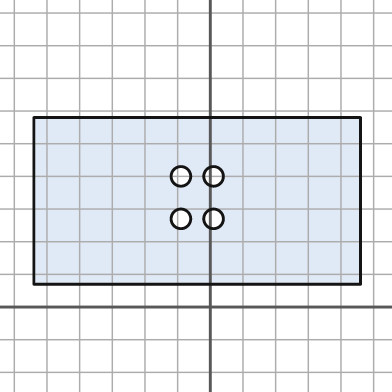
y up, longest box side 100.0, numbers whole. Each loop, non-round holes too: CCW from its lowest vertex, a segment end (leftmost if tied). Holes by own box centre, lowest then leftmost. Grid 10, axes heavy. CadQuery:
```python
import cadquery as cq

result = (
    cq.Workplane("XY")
    .moveTo(-54.0, 7.0)
    .lineTo(46.0, 7.0)
    .lineTo(46.0, 58.0)
    .lineTo(-54.0, 58.0)
    .close()
    .moveTo(-9.0, 27.0)
    .circle(3.0)
    .moveTo(1.0, 27.0)
    .circle(3.0)
    .moveTo(-9.0, 40.0)
    .circle(3.0)
    .moveTo(1.0, 40.0)
    .circle(3.0)
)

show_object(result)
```